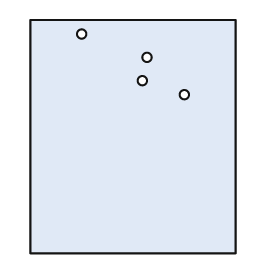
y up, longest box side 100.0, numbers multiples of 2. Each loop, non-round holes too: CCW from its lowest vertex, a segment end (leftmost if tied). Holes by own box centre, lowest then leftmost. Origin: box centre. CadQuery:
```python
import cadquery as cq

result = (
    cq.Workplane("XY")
    .moveTo(-44.0, -50.0)
    .lineTo(44.0, -50.0)
    .lineTo(44.0, 50.0)
    .lineTo(-44.0, 50.0)
    .close()
    .moveTo(22.0, 18.0)
    .circle(2.0)
    .moveTo(4.0, 24.0)
    .circle(2.0)
    .moveTo(6.0, 34.0)
    .circle(2.0)
    .moveTo(-22.0, 44.0)
    .circle(2.0)
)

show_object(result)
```